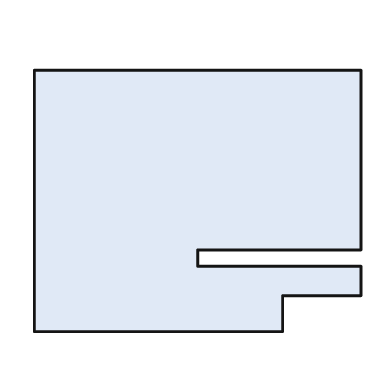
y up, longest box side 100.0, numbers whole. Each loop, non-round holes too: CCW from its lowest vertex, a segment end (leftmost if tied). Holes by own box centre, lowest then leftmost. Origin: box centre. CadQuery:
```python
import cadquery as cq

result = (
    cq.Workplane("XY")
    .moveTo(-50.0, -40.0)
    .lineTo(26.0, -40.0)
    .lineTo(26.0, -29.0)
    .lineTo(50.0, -29.0)
    .lineTo(50.0, -20.0)
    .lineTo(0.0, -20.0)
    .lineTo(0.0, -15.0)
    .lineTo(50.0, -15.0)
    .lineTo(50.0, 40.0)
    .lineTo(-50.0, 40.0)
    .close()
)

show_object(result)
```